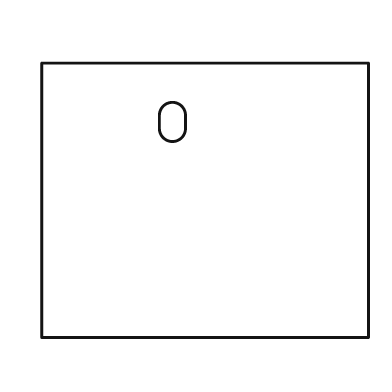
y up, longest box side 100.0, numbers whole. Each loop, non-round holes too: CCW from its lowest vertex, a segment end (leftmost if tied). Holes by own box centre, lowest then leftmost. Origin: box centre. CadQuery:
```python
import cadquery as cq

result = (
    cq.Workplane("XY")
    .moveTo(-50.0, -42.0)
    .lineTo(50.0, -42.0)
    .lineTo(50.0, 42.0)
    .lineTo(-50.0, 42.0)
    .close()
    .moveTo(-14.0, 22.0)
    .threePointArc((-10.0, 18.0), (-6.0, 22.0))
    .lineTo(-6.0, 26.0)
    .threePointArc((-10.0, 30.0), (-14.0, 26.0))
    .close()
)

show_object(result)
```